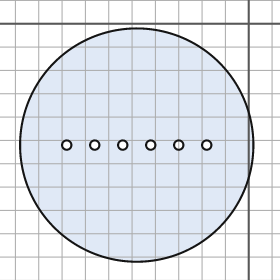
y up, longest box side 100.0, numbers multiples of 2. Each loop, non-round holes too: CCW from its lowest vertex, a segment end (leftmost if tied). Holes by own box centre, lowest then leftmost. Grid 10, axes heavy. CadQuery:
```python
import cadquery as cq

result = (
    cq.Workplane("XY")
    .moveTo(-48.0, -52.0)
    .circle(50.0)
    .moveTo(-78.0, -52.0)
    .circle(2.0)
    .moveTo(-66.0, -52.0)
    .circle(2.0)
    .moveTo(-54.0, -52.0)
    .circle(2.0)
    .moveTo(-42.0, -52.0)
    .circle(2.0)
    .moveTo(-30.0, -52.0)
    .circle(2.0)
    .moveTo(-18.0, -52.0)
    .circle(2.0)
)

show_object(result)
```